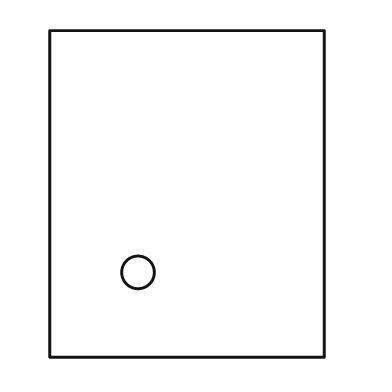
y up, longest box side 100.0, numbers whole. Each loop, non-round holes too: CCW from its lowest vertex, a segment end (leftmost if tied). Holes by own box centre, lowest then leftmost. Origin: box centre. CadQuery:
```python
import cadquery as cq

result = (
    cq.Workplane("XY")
    .moveTo(-42.0, -50.0)
    .lineTo(42.0, -50.0)
    .lineTo(42.0, 50.0)
    .lineTo(-42.0, 50.0)
    .close()
    .moveTo(-15.0, -24.0)
    .circle(5.0)
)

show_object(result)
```